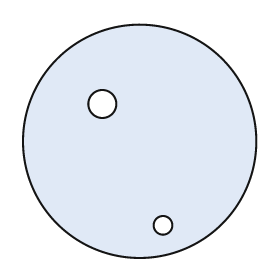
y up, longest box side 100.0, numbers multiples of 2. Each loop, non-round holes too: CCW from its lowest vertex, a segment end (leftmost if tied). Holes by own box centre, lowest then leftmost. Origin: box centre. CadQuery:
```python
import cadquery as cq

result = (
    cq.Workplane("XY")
    .moveTo(0.0, 0.0)
    .circle(50.0)
    .moveTo(10.0, -36.0)
    .circle(4.0)
    .moveTo(-16.0, 16.0)
    .circle(6.0)
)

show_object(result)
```